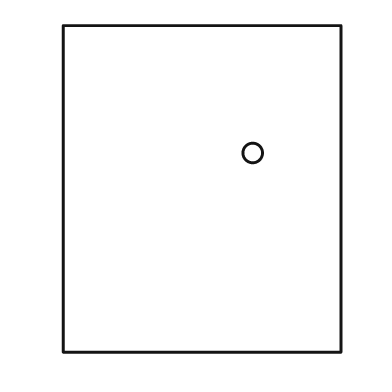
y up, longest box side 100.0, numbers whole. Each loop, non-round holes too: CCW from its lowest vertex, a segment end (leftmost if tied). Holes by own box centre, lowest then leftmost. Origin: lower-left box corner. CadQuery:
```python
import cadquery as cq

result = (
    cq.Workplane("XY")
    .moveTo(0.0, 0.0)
    .lineTo(85.0, 0.0)
    .lineTo(85.0, 100.0)
    .lineTo(0.0, 100.0)
    .close()
    .moveTo(58.0, 61.0)
    .circle(3.0)
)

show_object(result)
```